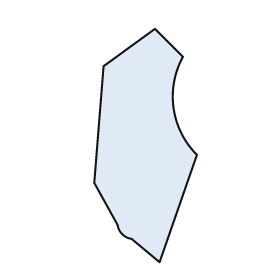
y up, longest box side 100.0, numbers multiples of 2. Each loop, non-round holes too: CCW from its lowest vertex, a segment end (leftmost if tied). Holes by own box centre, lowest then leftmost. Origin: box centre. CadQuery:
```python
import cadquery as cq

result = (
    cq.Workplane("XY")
    .moveTo(6.0, -50.0)
    .lineTo(22.0, -4.0)
    .threePointArc((12.0, 16.0), (16.0, 38.0))
    .lineTo(4.0, 50.0)
    .lineTo(-18.0, 34.0)
    .lineTo(-22.0, -16.0)
    .lineTo(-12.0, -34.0)
    .threePointArc((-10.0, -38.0), (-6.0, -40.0))
    .close()
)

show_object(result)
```